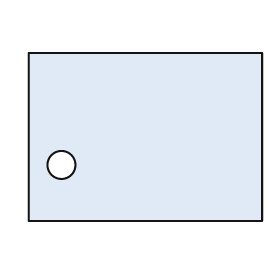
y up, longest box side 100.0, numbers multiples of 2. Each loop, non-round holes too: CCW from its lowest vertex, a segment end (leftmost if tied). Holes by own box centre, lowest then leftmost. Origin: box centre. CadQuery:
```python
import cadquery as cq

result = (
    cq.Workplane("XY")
    .moveTo(-50.0, -36.0)
    .lineTo(50.0, -36.0)
    .lineTo(50.0, 36.0)
    .lineTo(-50.0, 36.0)
    .close()
    .moveTo(-36.0, -12.0)
    .circle(6.0)
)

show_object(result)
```